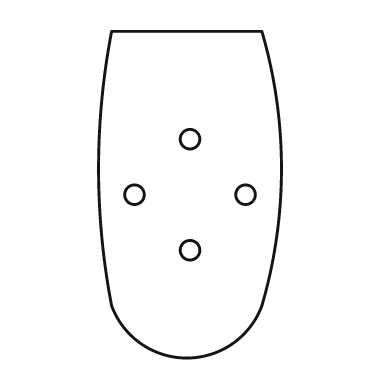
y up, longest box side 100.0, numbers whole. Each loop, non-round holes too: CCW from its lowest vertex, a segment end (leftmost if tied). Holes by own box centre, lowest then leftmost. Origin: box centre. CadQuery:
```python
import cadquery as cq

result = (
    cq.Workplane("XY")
    .moveTo(-24.0, -34.0)
    .threePointArc((-1.0, -50.0), (22.0, -34.0))
    .threePointArc((28.0, 8.0), (22.0, 50.0))
    .lineTo(-24.0, 50.0)
    .threePointArc((-28.0, 8.0), (-24.0, -34.0))
    .close()
    .moveTo(0.0, -17.0)
    .circle(3.0)
    .moveTo(-17.0, 0.0)
    .circle(3.0)
    .moveTo(17.0, 0.0)
    .circle(3.0)
    .moveTo(0.0, 17.0)
    .circle(3.0)
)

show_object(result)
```